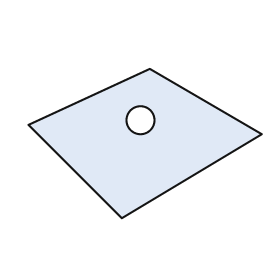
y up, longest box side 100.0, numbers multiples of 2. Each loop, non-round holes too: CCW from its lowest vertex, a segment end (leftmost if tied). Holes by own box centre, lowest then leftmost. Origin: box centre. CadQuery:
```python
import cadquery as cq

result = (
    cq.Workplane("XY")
    .moveTo(-10.0, -32.0)
    .lineTo(50.0, 4.0)
    .lineTo(2.0, 32.0)
    .lineTo(-50.0, 8.0)
    .close()
    .moveTo(-2.0, 10.0)
    .circle(6.0)
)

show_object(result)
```